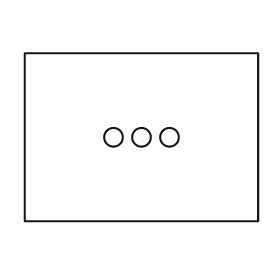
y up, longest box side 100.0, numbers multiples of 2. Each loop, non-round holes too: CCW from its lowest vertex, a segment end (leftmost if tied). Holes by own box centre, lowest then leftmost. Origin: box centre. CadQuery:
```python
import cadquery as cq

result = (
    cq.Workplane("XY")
    .moveTo(-50.0, -36.0)
    .lineTo(50.0, -36.0)
    .lineTo(50.0, 36.0)
    .lineTo(-50.0, 36.0)
    .close()
    .moveTo(-12.0, 0.0)
    .circle(4.0)
    .moveTo(0.0, 0.0)
    .circle(4.0)
    .moveTo(12.0, 0.0)
    .circle(4.0)
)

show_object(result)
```